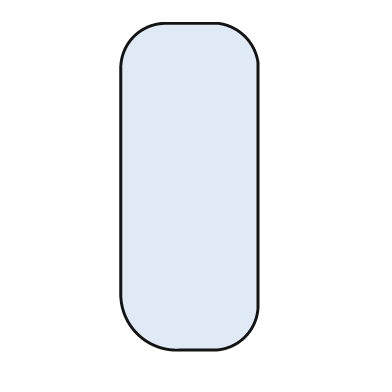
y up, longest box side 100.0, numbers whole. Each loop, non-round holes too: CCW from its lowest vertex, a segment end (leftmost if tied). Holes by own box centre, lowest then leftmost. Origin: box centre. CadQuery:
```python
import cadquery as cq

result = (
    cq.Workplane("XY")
    .moveTo(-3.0, -50.0)
    .lineTo(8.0, -50.0)
    .threePointArc((17.0, -46.0), (21.0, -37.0))
    .lineTo(21.0, 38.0)
    .threePointArc((17.0, 46.0), (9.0, 50.0))
    .lineTo(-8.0, 50.0)
    .threePointArc((-17.0, 46.0), (-21.0, 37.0))
    .lineTo(-21.0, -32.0)
    .threePointArc((-16.0, -45.0), (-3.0, -50.0))
    .close()
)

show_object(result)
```